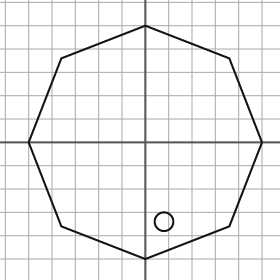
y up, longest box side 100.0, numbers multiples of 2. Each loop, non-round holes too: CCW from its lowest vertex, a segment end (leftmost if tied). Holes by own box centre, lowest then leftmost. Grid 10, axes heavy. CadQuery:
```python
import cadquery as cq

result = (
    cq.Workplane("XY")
    .moveTo(0.0, -50.0)
    .lineTo(36.0, -36.0)
    .lineTo(50.0, 0.0)
    .lineTo(36.0, 36.0)
    .lineTo(0.0, 50.0)
    .lineTo(-36.0, 36.0)
    .lineTo(-50.0, 0.0)
    .lineTo(-36.0, -36.0)
    .close()
    .moveTo(8.0, -34.0)
    .circle(4.0)
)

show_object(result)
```